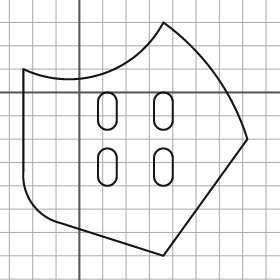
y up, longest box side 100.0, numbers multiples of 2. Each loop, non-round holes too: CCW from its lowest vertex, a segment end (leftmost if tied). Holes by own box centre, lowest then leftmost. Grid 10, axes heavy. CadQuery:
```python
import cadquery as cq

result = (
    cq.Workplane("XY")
    .moveTo(36.0, -70.0)
    .lineTo(72.0, -20.0)
    .threePointArc((58.0, 8.0), (36.0, 30.0))
    .threePointArc((10.0, 8.0), (-24.0, 10.0))
    .lineTo(-24.0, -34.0)
    .threePointArc((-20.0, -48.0), (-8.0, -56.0))
    .close()
    .moveTo(8.0, -36.0)
    .threePointArc((12.0, -40.0), (16.0, -36.0))
    .lineTo(16.0, -28.0)
    .threePointArc((12.0, -24.0), (8.0, -28.0))
    .close()
    .moveTo(32.0, -36.0)
    .threePointArc((36.0, -40.0), (40.0, -36.0))
    .lineTo(40.0, -28.0)
    .threePointArc((36.0, -24.0), (32.0, -28.0))
    .close()
    .moveTo(8.0, -12.0)
    .threePointArc((12.0, -16.0), (16.0, -12.0))
    .lineTo(16.0, -4.0)
    .threePointArc((12.0, 0.0), (8.0, -4.0))
    .close()
    .moveTo(32.0, -12.0)
    .threePointArc((36.0, -16.0), (40.0, -12.0))
    .lineTo(40.0, -4.0)
    .threePointArc((36.0, 0.0), (32.0, -4.0))
    .close()
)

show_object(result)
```